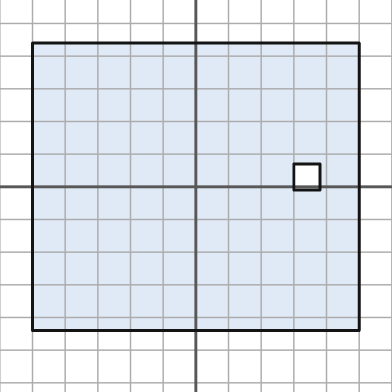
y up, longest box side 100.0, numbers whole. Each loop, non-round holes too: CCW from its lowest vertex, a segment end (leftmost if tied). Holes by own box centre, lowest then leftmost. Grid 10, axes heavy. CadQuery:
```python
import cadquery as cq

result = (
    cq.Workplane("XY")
    .moveTo(-50.0, -44.0)
    .lineTo(50.0, -44.0)
    .lineTo(50.0, 44.0)
    .lineTo(-50.0, 44.0)
    .close()
    .moveTo(30.0, -1.0)
    .lineTo(38.0, -1.0)
    .lineTo(38.0, 7.0)
    .lineTo(30.0, 7.0)
    .close()
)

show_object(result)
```